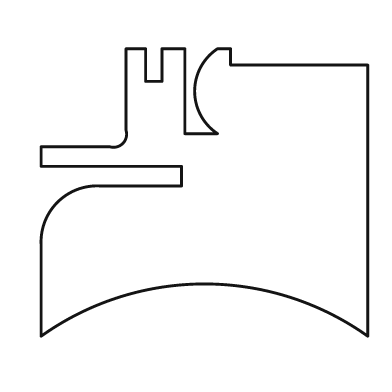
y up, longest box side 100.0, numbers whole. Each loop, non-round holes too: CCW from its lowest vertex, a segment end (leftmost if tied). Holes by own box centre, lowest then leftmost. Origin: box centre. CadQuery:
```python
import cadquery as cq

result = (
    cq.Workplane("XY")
    .moveTo(-50.0, -44.0)
    .threePointArc((0.0, -28.0), (50.0, -44.0))
    .lineTo(50.0, 39.0)
    .lineTo(8.0, 39.0)
    .lineTo(8.0, 44.0)
    .lineTo(4.0, 44.0)
    .threePointArc((-3.0, 31.0), (4.0, 18.0))
    .lineTo(-6.0, 18.0)
    .lineTo(-6.0, 44.0)
    .lineTo(-13.0, 44.0)
    .lineTo(-13.0, 34.0)
    .lineTo(-18.0, 34.0)
    .lineTo(-18.0, 44.0)
    .lineTo(-24.0, 44.0)
    .lineTo(-24.0, 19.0)
    .threePointArc((-25.0, 15.0), (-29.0, 14.0))
    .lineTo(-50.0, 14.0)
    .lineTo(-50.0, 8.0)
    .lineTo(-7.0, 8.0)
    .lineTo(-7.0, 2.0)
    .lineTo(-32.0, 2.0)
    .threePointArc((-45.0, -3.0), (-50.0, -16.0))
    .close()
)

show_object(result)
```